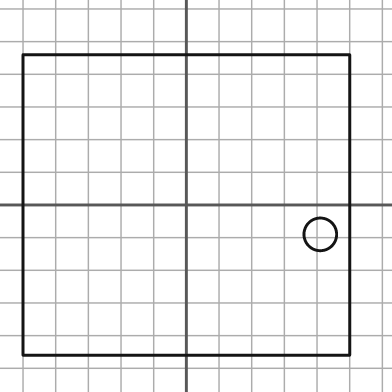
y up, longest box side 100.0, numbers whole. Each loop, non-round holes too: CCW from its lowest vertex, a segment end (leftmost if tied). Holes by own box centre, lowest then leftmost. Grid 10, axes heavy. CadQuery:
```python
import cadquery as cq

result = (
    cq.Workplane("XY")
    .moveTo(-50.0, -46.0)
    .lineTo(50.0, -46.0)
    .lineTo(50.0, 46.0)
    .lineTo(-50.0, 46.0)
    .close()
    .moveTo(41.0, -9.0)
    .circle(5.0)
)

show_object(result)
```